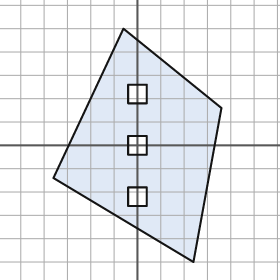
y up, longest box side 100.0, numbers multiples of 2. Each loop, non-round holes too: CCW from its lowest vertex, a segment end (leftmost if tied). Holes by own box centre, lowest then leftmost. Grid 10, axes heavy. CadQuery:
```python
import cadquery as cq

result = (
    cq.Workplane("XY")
    .moveTo(24.0, -50.0)
    .lineTo(36.0, 16.0)
    .lineTo(-6.0, 50.0)
    .lineTo(-36.0, -14.0)
    .close()
    .moveTo(-4.0, -26.0)
    .lineTo(4.0, -26.0)
    .lineTo(4.0, -18.0)
    .lineTo(-4.0, -18.0)
    .close()
    .moveTo(-4.0, -4.0)
    .lineTo(4.0, -4.0)
    .lineTo(4.0, 4.0)
    .lineTo(-4.0, 4.0)
    .close()
    .moveTo(-4.0, 18.0)
    .lineTo(4.0, 18.0)
    .lineTo(4.0, 26.0)
    .lineTo(-4.0, 26.0)
    .close()
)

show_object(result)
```